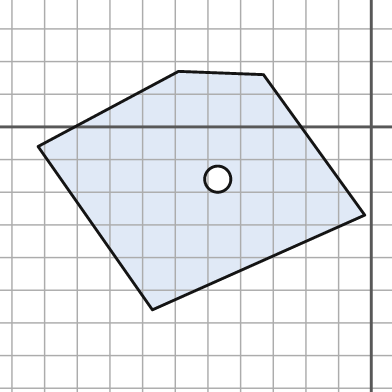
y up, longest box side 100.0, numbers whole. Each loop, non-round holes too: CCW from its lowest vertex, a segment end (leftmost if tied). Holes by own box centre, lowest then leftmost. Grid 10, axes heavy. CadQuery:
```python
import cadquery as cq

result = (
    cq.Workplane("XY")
    .moveTo(-67.0, -56.0)
    .lineTo(-2.0, -27.0)
    .lineTo(-33.0, 16.0)
    .lineTo(-59.0, 17.0)
    .lineTo(-102.0, -6.0)
    .close()
    .moveTo(-47.0, -16.0)
    .circle(4.0)
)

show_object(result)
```